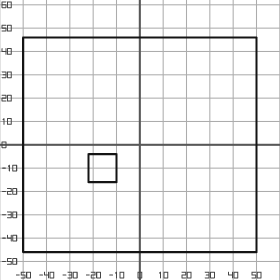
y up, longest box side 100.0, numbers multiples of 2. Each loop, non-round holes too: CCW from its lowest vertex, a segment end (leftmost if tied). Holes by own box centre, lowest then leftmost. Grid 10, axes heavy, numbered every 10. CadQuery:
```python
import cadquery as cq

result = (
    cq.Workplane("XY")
    .moveTo(-50.0, -46.0)
    .lineTo(50.0, -46.0)
    .lineTo(50.0, 46.0)
    .lineTo(-50.0, 46.0)
    .close()
    .moveTo(-22.0, -16.0)
    .lineTo(-10.0, -16.0)
    .lineTo(-10.0, -4.0)
    .lineTo(-22.0, -4.0)
    .close()
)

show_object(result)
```